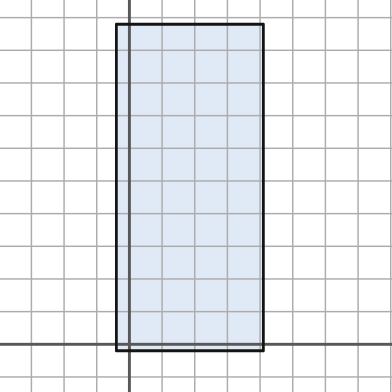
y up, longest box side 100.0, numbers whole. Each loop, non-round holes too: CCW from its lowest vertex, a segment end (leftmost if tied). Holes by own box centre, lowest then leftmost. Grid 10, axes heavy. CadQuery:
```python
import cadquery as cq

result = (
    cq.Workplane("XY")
    .moveTo(-4.0, -2.0)
    .lineTo(41.0, -2.0)
    .lineTo(41.0, 98.0)
    .lineTo(-4.0, 98.0)
    .close()
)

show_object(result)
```